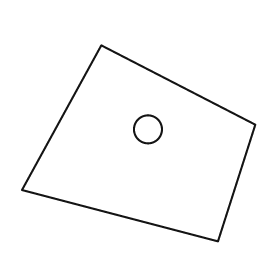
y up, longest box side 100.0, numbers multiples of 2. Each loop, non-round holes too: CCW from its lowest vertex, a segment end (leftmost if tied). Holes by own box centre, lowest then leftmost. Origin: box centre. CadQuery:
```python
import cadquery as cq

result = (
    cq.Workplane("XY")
    .moveTo(34.0, -42.0)
    .lineTo(50.0, 8.0)
    .lineTo(-16.0, 42.0)
    .lineTo(-50.0, -20.0)
    .close()
    .moveTo(4.0, 6.0)
    .circle(6.0)
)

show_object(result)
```